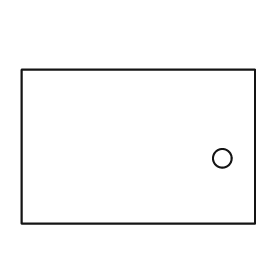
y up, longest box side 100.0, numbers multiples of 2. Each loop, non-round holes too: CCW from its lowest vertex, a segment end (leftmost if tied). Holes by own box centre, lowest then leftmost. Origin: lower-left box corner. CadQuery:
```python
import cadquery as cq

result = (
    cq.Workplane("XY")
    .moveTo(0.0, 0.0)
    .lineTo(100.0, 0.0)
    .lineTo(100.0, 66.0)
    .lineTo(0.0, 66.0)
    .close()
    .moveTo(86.0, 28.0)
    .circle(4.0)
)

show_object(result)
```